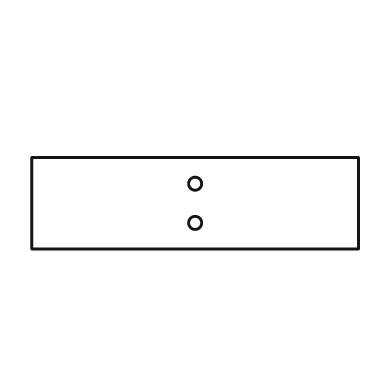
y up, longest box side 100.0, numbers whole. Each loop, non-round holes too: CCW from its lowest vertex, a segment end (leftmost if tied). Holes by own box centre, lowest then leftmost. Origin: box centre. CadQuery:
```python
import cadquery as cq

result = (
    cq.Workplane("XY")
    .moveTo(-50.0, -14.0)
    .lineTo(50.0, -14.0)
    .lineTo(50.0, 14.0)
    .lineTo(-50.0, 14.0)
    .close()
    .moveTo(0.0, -6.0)
    .circle(2.0)
    .moveTo(0.0, 6.0)
    .circle(2.0)
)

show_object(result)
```